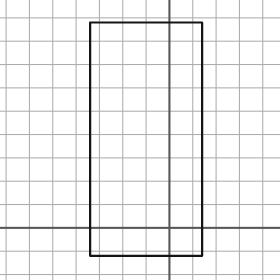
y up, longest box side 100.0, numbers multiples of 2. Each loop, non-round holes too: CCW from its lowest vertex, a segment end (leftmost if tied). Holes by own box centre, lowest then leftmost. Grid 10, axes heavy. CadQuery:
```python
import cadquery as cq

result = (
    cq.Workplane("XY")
    .moveTo(-34.0, -12.0)
    .lineTo(14.0, -12.0)
    .lineTo(14.0, 88.0)
    .lineTo(-34.0, 88.0)
    .close()
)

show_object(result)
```